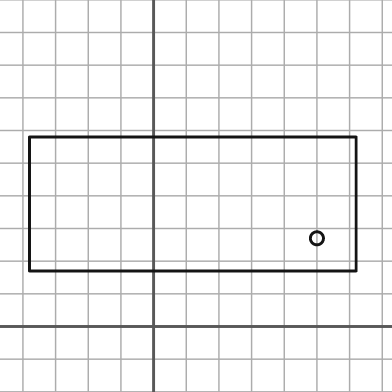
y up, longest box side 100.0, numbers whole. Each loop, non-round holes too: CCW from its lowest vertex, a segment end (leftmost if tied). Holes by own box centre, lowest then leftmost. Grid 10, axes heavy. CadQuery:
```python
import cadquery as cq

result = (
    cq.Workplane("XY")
    .moveTo(-38.0, 17.0)
    .lineTo(62.0, 17.0)
    .lineTo(62.0, 58.0)
    .lineTo(-38.0, 58.0)
    .close()
    .moveTo(50.0, 27.0)
    .circle(2.0)
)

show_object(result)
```